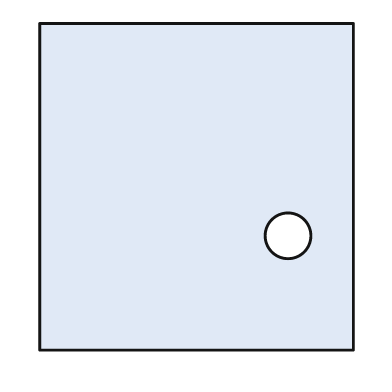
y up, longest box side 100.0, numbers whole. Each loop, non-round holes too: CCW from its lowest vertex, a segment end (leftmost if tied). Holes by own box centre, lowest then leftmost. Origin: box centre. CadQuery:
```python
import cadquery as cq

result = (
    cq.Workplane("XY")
    .moveTo(-48.0, -50.0)
    .lineTo(48.0, -50.0)
    .lineTo(48.0, 50.0)
    .lineTo(-48.0, 50.0)
    .close()
    .moveTo(28.0, -15.0)
    .circle(7.0)
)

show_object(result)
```